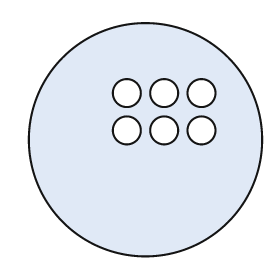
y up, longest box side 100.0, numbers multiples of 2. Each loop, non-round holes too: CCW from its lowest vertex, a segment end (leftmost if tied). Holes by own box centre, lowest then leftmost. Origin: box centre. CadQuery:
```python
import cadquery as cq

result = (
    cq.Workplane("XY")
    .moveTo(0.0, 0.0)
    .circle(50.0)
    .moveTo(-8.0, 4.0)
    .circle(6.0)
    .moveTo(8.0, 4.0)
    .circle(6.0)
    .moveTo(24.0, 4.0)
    .circle(6.0)
    .moveTo(-8.0, 20.0)
    .circle(6.0)
    .moveTo(8.0, 20.0)
    .circle(6.0)
    .moveTo(24.0, 20.0)
    .circle(6.0)
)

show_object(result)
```